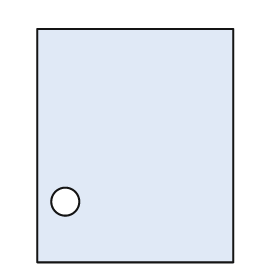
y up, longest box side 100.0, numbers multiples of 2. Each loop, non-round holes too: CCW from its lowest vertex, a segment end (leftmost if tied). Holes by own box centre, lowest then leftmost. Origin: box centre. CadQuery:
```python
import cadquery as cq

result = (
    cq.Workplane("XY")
    .moveTo(-42.0, -50.0)
    .lineTo(42.0, -50.0)
    .lineTo(42.0, 50.0)
    .lineTo(-42.0, 50.0)
    .close()
    .moveTo(-30.0, -24.0)
    .circle(6.0)
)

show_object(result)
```